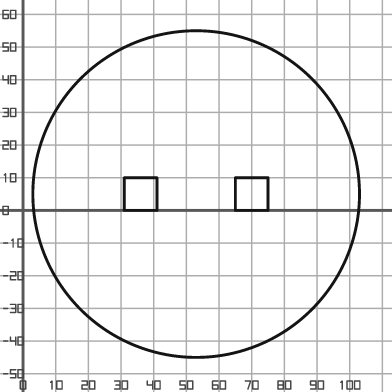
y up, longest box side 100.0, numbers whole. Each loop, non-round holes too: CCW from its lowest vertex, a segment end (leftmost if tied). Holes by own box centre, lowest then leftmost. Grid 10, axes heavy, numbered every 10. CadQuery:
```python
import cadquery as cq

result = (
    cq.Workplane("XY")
    .moveTo(53.0, 5.0)
    .circle(50.0)
    .moveTo(31.0, 0.0)
    .lineTo(41.0, 0.0)
    .lineTo(41.0, 10.0)
    .lineTo(31.0, 10.0)
    .close()
    .moveTo(65.0, 0.0)
    .lineTo(75.0, 0.0)
    .lineTo(75.0, 10.0)
    .lineTo(65.0, 10.0)
    .close()
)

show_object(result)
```